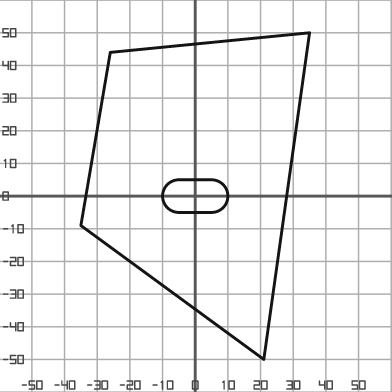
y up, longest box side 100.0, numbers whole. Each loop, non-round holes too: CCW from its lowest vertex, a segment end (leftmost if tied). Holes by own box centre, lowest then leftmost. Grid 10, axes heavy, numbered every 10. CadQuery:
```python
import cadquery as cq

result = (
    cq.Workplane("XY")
    .moveTo(21.0, -50.0)
    .lineTo(35.0, 50.0)
    .lineTo(-26.0, 44.0)
    .lineTo(-35.0, -9.0)
    .close()
    .moveTo(-5.0, -5.0)
    .lineTo(5.0, -5.0)
    .threePointArc((10.0, 0.0), (5.0, 5.0))
    .lineTo(-5.0, 5.0)
    .threePointArc((-10.0, 0.0), (-5.0, -5.0))
    .close()
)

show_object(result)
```